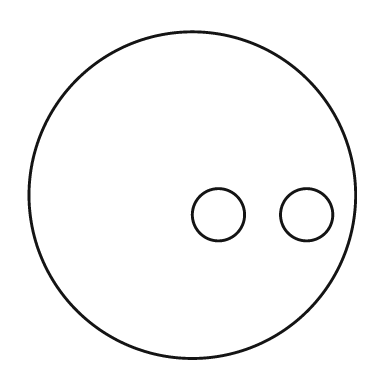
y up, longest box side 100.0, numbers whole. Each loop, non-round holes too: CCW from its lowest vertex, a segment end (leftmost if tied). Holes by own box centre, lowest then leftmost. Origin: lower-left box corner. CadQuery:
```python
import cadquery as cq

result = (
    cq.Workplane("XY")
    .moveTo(50.0, 50.0)
    .circle(50.0)
    .moveTo(58.0, 44.0)
    .circle(8.0)
    .moveTo(85.0, 44.0)
    .circle(8.0)
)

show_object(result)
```